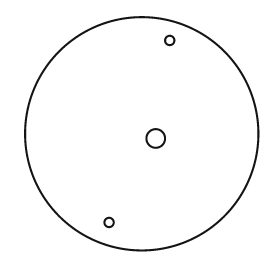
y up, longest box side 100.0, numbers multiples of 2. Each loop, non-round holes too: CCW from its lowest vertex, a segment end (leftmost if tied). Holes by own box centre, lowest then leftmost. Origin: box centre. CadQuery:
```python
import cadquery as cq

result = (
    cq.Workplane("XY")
    .moveTo(0.0, 0.0)
    .circle(50.0)
    .moveTo(-14.0, -38.0)
    .circle(2.0)
    .moveTo(6.0, -2.0)
    .circle(4.0)
    .moveTo(12.0, 40.0)
    .circle(2.0)
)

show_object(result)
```